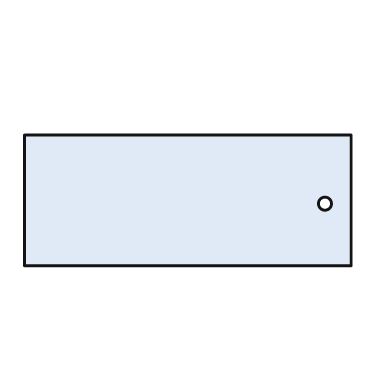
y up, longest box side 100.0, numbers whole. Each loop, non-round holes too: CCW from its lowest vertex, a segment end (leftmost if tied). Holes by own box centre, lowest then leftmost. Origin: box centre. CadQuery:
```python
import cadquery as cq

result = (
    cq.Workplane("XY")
    .moveTo(-50.0, -20.0)
    .lineTo(50.0, -20.0)
    .lineTo(50.0, 20.0)
    .lineTo(-50.0, 20.0)
    .close()
    .moveTo(42.0, -1.0)
    .circle(2.0)
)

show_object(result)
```